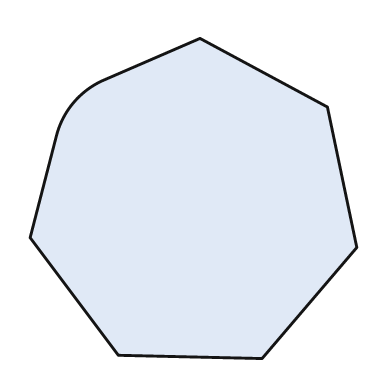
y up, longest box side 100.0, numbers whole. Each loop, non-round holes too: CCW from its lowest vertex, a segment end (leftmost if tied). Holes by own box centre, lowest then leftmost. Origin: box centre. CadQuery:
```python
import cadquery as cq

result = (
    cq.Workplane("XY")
    .moveTo(21.0, -49.0)
    .lineTo(50.0, -15.0)
    .lineTo(41.0, 28.0)
    .lineTo(2.0, 49.0)
    .lineTo(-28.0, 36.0)
    .threePointArc((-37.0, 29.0), (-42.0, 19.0))
    .lineTo(-50.0, -12.0)
    .lineTo(-23.0, -48.0)
    .close()
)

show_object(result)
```